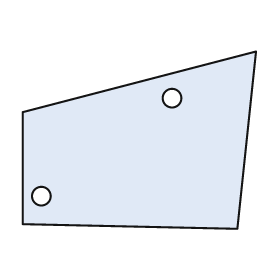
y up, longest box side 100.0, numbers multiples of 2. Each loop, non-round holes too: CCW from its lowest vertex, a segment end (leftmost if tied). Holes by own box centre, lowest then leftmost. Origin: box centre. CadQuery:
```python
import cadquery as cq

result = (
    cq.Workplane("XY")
    .moveTo(42.0, -38.0)
    .lineTo(50.0, 38.0)
    .lineTo(-50.0, 12.0)
    .lineTo(-50.0, -36.0)
    .close()
    .moveTo(-42.0, -24.0)
    .circle(4.0)
    .moveTo(14.0, 18.0)
    .circle(4.0)
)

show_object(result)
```